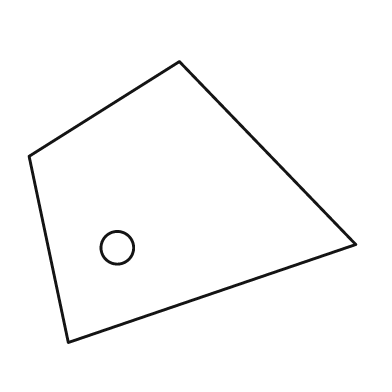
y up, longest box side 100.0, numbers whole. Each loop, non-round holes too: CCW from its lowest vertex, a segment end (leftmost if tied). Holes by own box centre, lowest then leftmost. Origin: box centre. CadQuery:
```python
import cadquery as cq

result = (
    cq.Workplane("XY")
    .moveTo(-38.0, -43.0)
    .lineTo(50.0, -13.0)
    .lineTo(-4.0, 43.0)
    .lineTo(-50.0, 14.0)
    .close()
    .moveTo(-23.0, -14.0)
    .circle(5.0)
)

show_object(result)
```